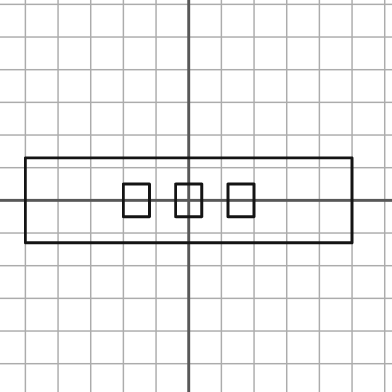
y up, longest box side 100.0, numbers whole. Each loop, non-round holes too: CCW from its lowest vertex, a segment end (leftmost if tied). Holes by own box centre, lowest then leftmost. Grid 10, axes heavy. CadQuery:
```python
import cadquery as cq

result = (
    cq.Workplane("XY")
    .moveTo(-50.0, -13.0)
    .lineTo(50.0, -13.0)
    .lineTo(50.0, 13.0)
    .lineTo(-50.0, 13.0)
    .close()
    .moveTo(-20.0, -5.0)
    .lineTo(-12.0, -5.0)
    .lineTo(-12.0, 5.0)
    .lineTo(-20.0, 5.0)
    .close()
    .moveTo(-4.0, -5.0)
    .lineTo(4.0, -5.0)
    .lineTo(4.0, 5.0)
    .lineTo(-4.0, 5.0)
    .close()
    .moveTo(12.0, -5.0)
    .lineTo(20.0, -5.0)
    .lineTo(20.0, 5.0)
    .lineTo(12.0, 5.0)
    .close()
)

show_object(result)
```